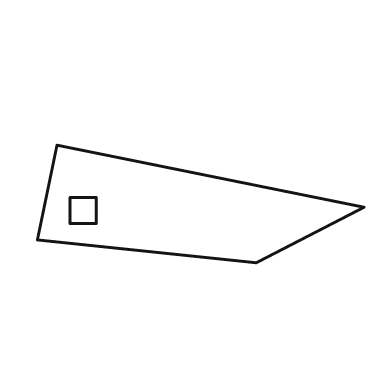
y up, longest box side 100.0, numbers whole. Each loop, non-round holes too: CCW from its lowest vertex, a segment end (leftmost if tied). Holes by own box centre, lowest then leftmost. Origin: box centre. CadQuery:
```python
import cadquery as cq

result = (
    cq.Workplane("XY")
    .moveTo(17.0, -18.0)
    .lineTo(50.0, -1.0)
    .lineTo(-44.0, 18.0)
    .lineTo(-50.0, -11.0)
    .close()
    .moveTo(-40.0, -6.0)
    .lineTo(-32.0, -6.0)
    .lineTo(-32.0, 2.0)
    .lineTo(-40.0, 2.0)
    .close()
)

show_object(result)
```